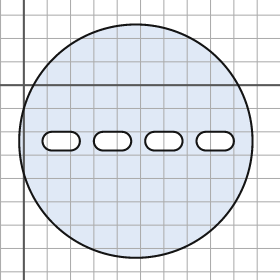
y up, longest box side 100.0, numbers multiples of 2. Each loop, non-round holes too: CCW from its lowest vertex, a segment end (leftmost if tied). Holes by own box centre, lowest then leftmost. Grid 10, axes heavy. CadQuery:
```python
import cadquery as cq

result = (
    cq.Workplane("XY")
    .moveTo(48.0, -24.0)
    .circle(50.0)
    .moveTo(12.0, -28.0)
    .lineTo(20.0, -28.0)
    .threePointArc((24.0, -24.0), (20.0, -20.0))
    .lineTo(12.0, -20.0)
    .threePointArc((8.0, -24.0), (12.0, -28.0))
    .close()
    .moveTo(34.0, -28.0)
    .lineTo(42.0, -28.0)
    .threePointArc((46.0, -24.0), (42.0, -20.0))
    .lineTo(34.0, -20.0)
    .threePointArc((30.0, -24.0), (34.0, -28.0))
    .close()
    .moveTo(56.0, -28.0)
    .lineTo(64.0, -28.0)
    .threePointArc((68.0, -24.0), (64.0, -20.0))
    .lineTo(56.0, -20.0)
    .threePointArc((52.0, -24.0), (56.0, -28.0))
    .close()
    .moveTo(78.0, -28.0)
    .lineTo(86.0, -28.0)
    .threePointArc((90.0, -24.0), (86.0, -20.0))
    .lineTo(78.0, -20.0)
    .threePointArc((74.0, -24.0), (78.0, -28.0))
    .close()
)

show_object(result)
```